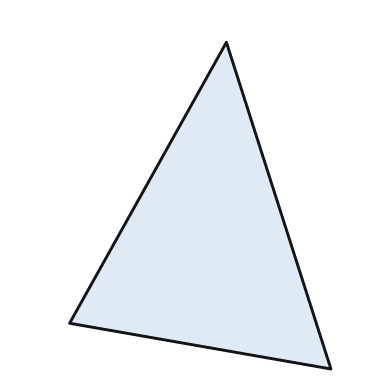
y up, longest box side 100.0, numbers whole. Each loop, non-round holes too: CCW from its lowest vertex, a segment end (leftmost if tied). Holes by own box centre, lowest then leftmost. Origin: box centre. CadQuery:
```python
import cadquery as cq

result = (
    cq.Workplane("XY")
    .moveTo(40.0, -50.0)
    .lineTo(8.0, 50.0)
    .lineTo(-40.0, -36.0)
    .close()
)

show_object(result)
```